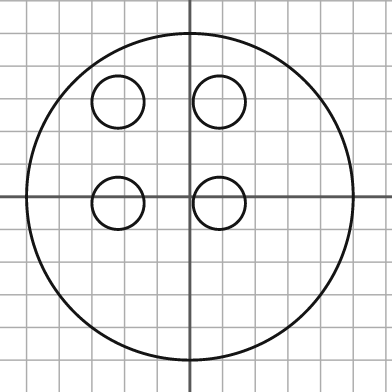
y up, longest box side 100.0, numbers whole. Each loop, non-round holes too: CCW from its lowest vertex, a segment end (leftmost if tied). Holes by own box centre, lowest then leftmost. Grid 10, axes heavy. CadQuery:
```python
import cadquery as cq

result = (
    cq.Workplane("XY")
    .moveTo(0.0, 0.0)
    .circle(50.0)
    .moveTo(-22.0, -2.0)
    .circle(8.0)
    .moveTo(9.0, -2.0)
    .circle(8.0)
    .moveTo(-22.0, 29.0)
    .circle(8.0)
    .moveTo(9.0, 29.0)
    .circle(8.0)
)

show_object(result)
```